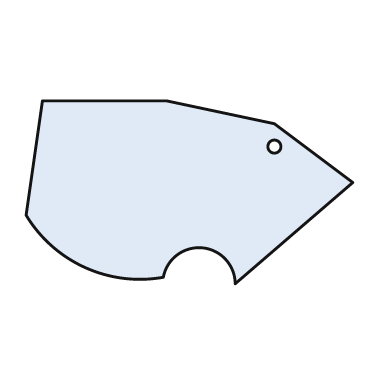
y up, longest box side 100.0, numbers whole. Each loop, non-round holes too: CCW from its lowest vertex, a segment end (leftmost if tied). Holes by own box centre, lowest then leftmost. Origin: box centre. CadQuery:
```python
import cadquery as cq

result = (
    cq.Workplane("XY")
    .moveTo(14.0, -28.0)
    .lineTo(50.0, 3.0)
    .lineTo(26.0, 21.0)
    .lineTo(-7.0, 28.0)
    .lineTo(-45.0, 28.0)
    .lineTo(-50.0, -7.0)
    .threePointArc((-32.0, -23.0), (-8.0, -26.0))
    .threePointArc((4.0, -17.0), (14.0, -28.0))
    .close()
    .moveTo(26.0, 14.0)
    .circle(2.0)
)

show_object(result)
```